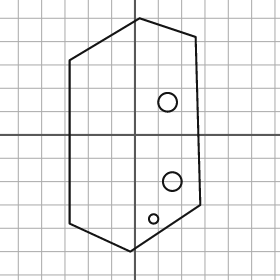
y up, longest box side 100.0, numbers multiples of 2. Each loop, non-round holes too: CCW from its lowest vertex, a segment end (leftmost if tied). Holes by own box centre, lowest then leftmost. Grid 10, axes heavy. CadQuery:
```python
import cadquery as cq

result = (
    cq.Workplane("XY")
    .moveTo(-2.0, -50.0)
    .lineTo(28.0, -30.0)
    .lineTo(26.0, 42.0)
    .lineTo(2.0, 50.0)
    .lineTo(-28.0, 32.0)
    .lineTo(-28.0, -38.0)
    .close()
    .moveTo(8.0, -36.0)
    .circle(2.0)
    .moveTo(16.0, -20.0)
    .circle(4.0)
    .moveTo(14.0, 14.0)
    .circle(4.0)
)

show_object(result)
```